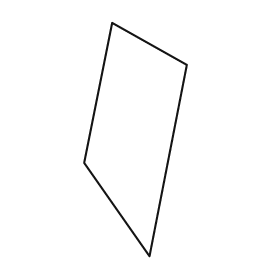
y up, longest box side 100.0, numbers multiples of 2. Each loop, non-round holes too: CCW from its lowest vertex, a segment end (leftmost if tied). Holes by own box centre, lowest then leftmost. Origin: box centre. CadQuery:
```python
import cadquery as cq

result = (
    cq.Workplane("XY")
    .moveTo(6.0, -50.0)
    .lineTo(22.0, 32.0)
    .lineTo(-10.0, 50.0)
    .lineTo(-22.0, -10.0)
    .close()
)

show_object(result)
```